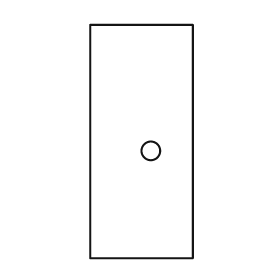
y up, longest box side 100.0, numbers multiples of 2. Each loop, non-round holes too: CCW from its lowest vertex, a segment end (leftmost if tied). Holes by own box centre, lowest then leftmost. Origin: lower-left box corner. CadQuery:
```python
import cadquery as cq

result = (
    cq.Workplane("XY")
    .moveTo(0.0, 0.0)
    .lineTo(44.0, 0.0)
    .lineTo(44.0, 100.0)
    .lineTo(0.0, 100.0)
    .close()
    .moveTo(26.0, 46.0)
    .circle(4.0)
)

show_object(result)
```